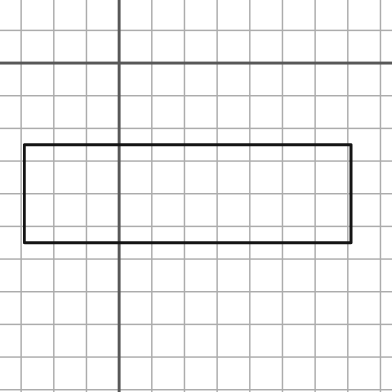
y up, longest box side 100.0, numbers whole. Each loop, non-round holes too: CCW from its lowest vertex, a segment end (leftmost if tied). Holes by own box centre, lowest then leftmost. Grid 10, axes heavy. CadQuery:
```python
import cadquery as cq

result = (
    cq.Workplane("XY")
    .moveTo(-29.0, -55.0)
    .lineTo(71.0, -55.0)
    .lineTo(71.0, -25.0)
    .lineTo(-29.0, -25.0)
    .close()
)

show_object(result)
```